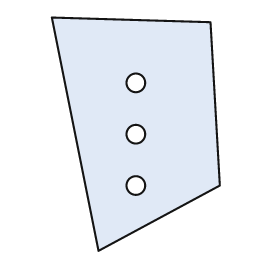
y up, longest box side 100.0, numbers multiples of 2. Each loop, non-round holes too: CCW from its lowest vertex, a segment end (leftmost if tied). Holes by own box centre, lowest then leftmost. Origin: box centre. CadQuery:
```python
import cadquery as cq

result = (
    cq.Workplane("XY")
    .moveTo(-16.0, -50.0)
    .lineTo(36.0, -22.0)
    .lineTo(32.0, 48.0)
    .lineTo(-36.0, 50.0)
    .close()
    .moveTo(0.0, -22.0)
    .circle(4.0)
    .moveTo(0.0, 0.0)
    .circle(4.0)
    .moveTo(0.0, 22.0)
    .circle(4.0)
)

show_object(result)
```